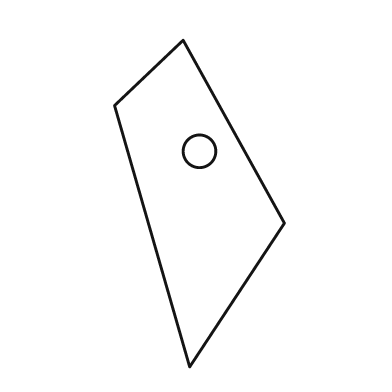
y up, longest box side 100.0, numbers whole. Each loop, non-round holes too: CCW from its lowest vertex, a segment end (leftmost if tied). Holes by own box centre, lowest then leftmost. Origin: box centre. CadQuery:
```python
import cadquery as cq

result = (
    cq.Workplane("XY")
    .moveTo(-3.0, -50.0)
    .lineTo(26.0, -6.0)
    .lineTo(-5.0, 50.0)
    .lineTo(-26.0, 30.0)
    .close()
    .moveTo(0.0, 16.0)
    .circle(5.0)
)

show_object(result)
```